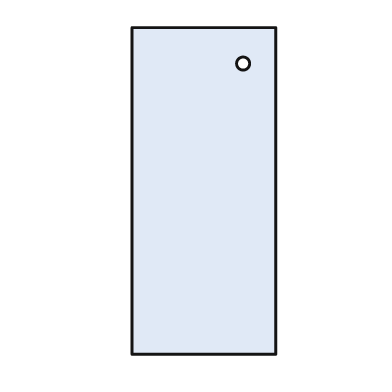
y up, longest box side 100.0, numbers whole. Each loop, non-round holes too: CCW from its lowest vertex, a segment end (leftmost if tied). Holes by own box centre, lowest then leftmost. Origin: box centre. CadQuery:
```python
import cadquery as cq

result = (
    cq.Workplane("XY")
    .moveTo(-22.0, -50.0)
    .lineTo(22.0, -50.0)
    .lineTo(22.0, 50.0)
    .lineTo(-22.0, 50.0)
    .close()
    .moveTo(12.0, 39.0)
    .circle(2.0)
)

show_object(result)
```